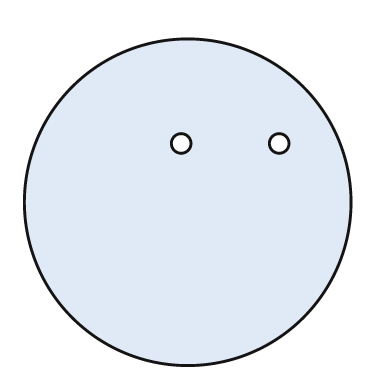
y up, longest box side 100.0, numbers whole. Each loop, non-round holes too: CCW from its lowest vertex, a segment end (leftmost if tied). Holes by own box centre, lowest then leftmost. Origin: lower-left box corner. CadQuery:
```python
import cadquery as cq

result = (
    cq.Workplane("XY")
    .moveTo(50.0, 50.0)
    .circle(50.0)
    .moveTo(48.0, 68.0)
    .circle(3.0)
    .moveTo(78.0, 68.0)
    .circle(3.0)
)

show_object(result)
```